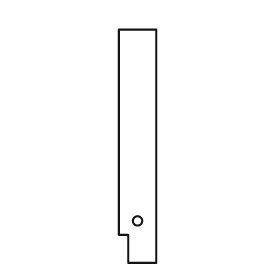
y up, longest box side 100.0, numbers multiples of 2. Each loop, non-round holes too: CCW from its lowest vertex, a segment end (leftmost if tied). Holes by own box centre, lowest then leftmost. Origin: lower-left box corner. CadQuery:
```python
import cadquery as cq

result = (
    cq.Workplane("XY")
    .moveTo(4.0, 0.0)
    .lineTo(16.0, 0.0)
    .lineTo(16.0, 100.0)
    .lineTo(0.0, 100.0)
    .lineTo(0.0, 12.0)
    .lineTo(4.0, 12.0)
    .close()
    .moveTo(8.0, 18.0)
    .circle(2.0)
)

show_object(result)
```